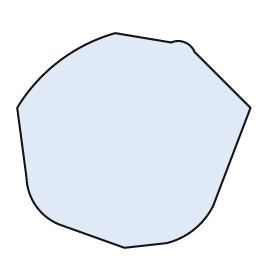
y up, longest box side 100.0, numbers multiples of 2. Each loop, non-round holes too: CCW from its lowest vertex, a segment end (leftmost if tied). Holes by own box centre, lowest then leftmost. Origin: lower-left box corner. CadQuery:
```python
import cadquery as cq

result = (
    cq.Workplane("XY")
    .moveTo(46.0, 0.0)
    .lineTo(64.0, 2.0)
    .threePointArc((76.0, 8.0), (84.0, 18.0))
    .lineTo(100.0, 60.0)
    .lineTo(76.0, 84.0)
    .threePointArc((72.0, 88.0), (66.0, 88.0))
    .lineTo(42.0, 92.0)
    .threePointArc((18.0, 80.0), (0.0, 60.0))
    .lineTo(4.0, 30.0)
    .threePointArc((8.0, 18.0), (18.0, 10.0))
    .close()
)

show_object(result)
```